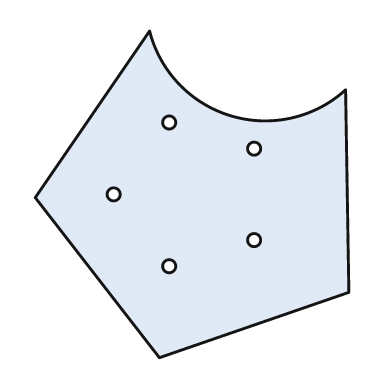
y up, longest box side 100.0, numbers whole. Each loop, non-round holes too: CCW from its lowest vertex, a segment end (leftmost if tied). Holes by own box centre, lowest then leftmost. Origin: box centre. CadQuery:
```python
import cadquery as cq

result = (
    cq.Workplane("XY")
    .moveTo(-10.0, -50.0)
    .lineTo(48.0, -30.0)
    .lineTo(47.0, 32.0)
    .threePointArc((12.0, 24.0), (-13.0, 50.0))
    .lineTo(-48.0, -1.0)
    .close()
    .moveTo(-7.0, -22.0)
    .circle(2.0)
    .moveTo(19.0, -14.0)
    .circle(2.0)
    .moveTo(-24.0, 0.0)
    .circle(2.0)
    .moveTo(19.0, 14.0)
    .circle(2.0)
    .moveTo(-7.0, 22.0)
    .circle(2.0)
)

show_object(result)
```